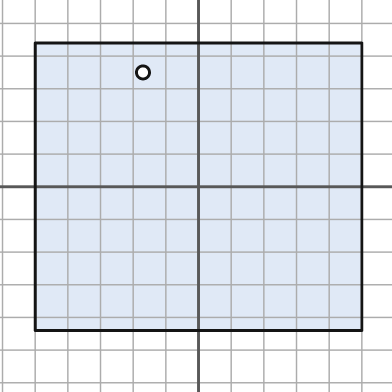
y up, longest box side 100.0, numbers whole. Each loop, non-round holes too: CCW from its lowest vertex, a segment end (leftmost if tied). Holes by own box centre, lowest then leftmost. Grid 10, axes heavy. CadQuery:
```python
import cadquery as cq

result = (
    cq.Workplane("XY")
    .moveTo(-50.0, -44.0)
    .lineTo(50.0, -44.0)
    .lineTo(50.0, 44.0)
    .lineTo(-50.0, 44.0)
    .close()
    .moveTo(-17.0, 35.0)
    .circle(2.0)
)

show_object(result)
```